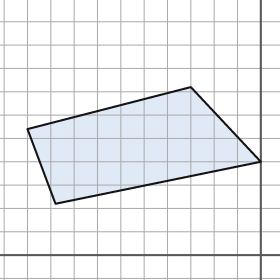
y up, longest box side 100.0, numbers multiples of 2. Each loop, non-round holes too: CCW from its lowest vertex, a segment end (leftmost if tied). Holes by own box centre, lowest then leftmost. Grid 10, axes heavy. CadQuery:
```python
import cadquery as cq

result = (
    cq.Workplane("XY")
    .moveTo(-88.0, 22.0)
    .lineTo(0.0, 40.0)
    .lineTo(-30.0, 72.0)
    .lineTo(-100.0, 54.0)
    .close()
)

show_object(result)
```